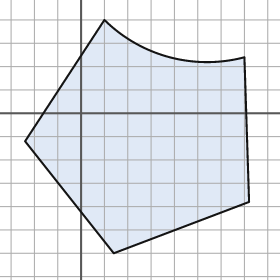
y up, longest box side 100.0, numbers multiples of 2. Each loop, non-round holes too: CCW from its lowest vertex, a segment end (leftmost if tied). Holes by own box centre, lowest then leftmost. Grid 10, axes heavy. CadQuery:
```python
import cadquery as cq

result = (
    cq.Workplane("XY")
    .moveTo(14.0, -60.0)
    .lineTo(72.0, -38.0)
    .lineTo(70.0, 24.0)
    .threePointArc((38.0, 24.0), (10.0, 40.0))
    .lineTo(-24.0, -12.0)
    .close()
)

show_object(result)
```